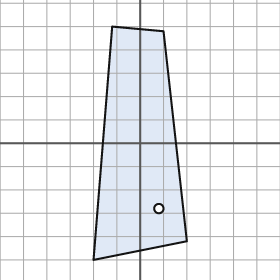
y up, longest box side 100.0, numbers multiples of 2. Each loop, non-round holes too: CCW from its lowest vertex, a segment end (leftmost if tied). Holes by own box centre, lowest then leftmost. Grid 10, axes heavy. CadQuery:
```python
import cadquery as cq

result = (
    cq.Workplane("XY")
    .moveTo(-20.0, -50.0)
    .lineTo(20.0, -42.0)
    .lineTo(10.0, 48.0)
    .lineTo(-12.0, 50.0)
    .close()
    .moveTo(8.0, -28.0)
    .circle(2.0)
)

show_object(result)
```